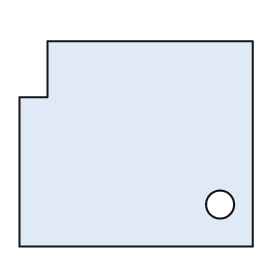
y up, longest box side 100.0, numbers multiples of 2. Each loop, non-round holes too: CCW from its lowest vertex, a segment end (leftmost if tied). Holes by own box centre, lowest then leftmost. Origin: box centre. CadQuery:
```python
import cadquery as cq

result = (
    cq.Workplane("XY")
    .moveTo(-50.0, -44.0)
    .lineTo(50.0, -44.0)
    .lineTo(50.0, 44.0)
    .lineTo(-38.0, 44.0)
    .lineTo(-38.0, 20.0)
    .lineTo(-50.0, 20.0)
    .close()
    .moveTo(36.0, -26.0)
    .circle(6.0)
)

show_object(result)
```